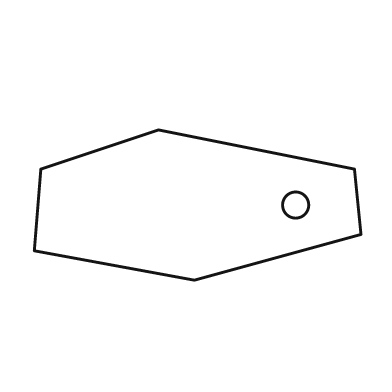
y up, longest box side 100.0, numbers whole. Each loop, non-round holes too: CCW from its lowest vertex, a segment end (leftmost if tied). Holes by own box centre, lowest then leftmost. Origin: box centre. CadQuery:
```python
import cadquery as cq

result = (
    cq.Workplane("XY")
    .moveTo(-1.0, -23.0)
    .lineTo(50.0, -9.0)
    .lineTo(48.0, 11.0)
    .lineTo(-12.0, 23.0)
    .lineTo(-48.0, 11.0)
    .lineTo(-50.0, -14.0)
    .close()
    .moveTo(30.0, 0.0)
    .circle(4.0)
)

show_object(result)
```